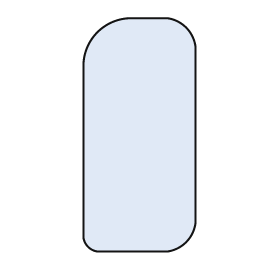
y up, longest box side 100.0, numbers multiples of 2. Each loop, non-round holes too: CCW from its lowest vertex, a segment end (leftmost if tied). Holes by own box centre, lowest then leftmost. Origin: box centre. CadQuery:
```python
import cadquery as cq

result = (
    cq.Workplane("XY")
    .moveTo(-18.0, -50.0)
    .lineTo(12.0, -50.0)
    .threePointArc((20.0, -46.0), (24.0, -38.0))
    .lineTo(24.0, 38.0)
    .threePointArc((20.0, 46.0), (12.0, 50.0))
    .lineTo(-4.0, 50.0)
    .threePointArc((-18.0, 44.0), (-24.0, 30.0))
    .lineTo(-24.0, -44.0)
    .threePointArc((-22.0, -48.0), (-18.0, -50.0))
    .close()
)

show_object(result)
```